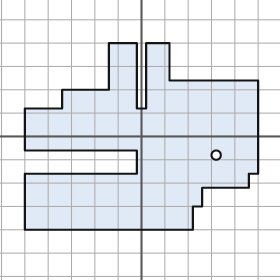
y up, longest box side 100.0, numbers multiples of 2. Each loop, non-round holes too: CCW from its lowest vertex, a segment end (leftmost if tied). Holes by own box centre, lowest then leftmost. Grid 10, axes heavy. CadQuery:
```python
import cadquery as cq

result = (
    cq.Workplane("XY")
    .moveTo(-50.0, -40.0)
    .lineTo(22.0, -40.0)
    .lineTo(22.0, -30.0)
    .lineTo(26.0, -30.0)
    .lineTo(26.0, -22.0)
    .lineTo(46.0, -22.0)
    .lineTo(46.0, -16.0)
    .lineTo(50.0, -16.0)
    .lineTo(50.0, 24.0)
    .lineTo(12.0, 24.0)
    .lineTo(12.0, 40.0)
    .lineTo(2.0, 40.0)
    .lineTo(2.0, 12.0)
    .lineTo(-2.0, 12.0)
    .lineTo(-2.0, 40.0)
    .lineTo(-14.0, 40.0)
    .lineTo(-14.0, 20.0)
    .lineTo(-34.0, 20.0)
    .lineTo(-34.0, 12.0)
    .lineTo(-50.0, 12.0)
    .lineTo(-50.0, -6.0)
    .lineTo(-2.0, -6.0)
    .lineTo(-2.0, -16.0)
    .lineTo(-50.0, -16.0)
    .close()
    .moveTo(32.0, -8.0)
    .circle(2.0)
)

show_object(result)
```